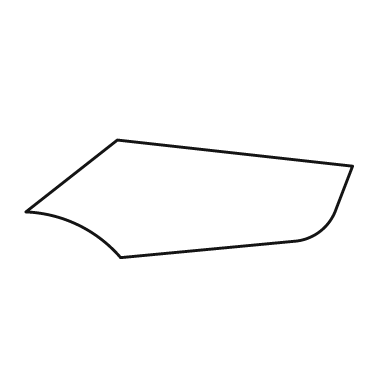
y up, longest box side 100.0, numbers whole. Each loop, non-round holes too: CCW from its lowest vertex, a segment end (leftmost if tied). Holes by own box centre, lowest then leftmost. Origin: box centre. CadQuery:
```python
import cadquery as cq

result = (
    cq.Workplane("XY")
    .moveTo(-21.0, -18.0)
    .lineTo(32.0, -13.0)
    .threePointArc((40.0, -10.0), (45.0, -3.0))
    .lineTo(50.0, 10.0)
    .lineTo(-22.0, 18.0)
    .lineTo(-50.0, -4.0)
    .threePointArc((-34.0, -8.0), (-21.0, -18.0))
    .close()
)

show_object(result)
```